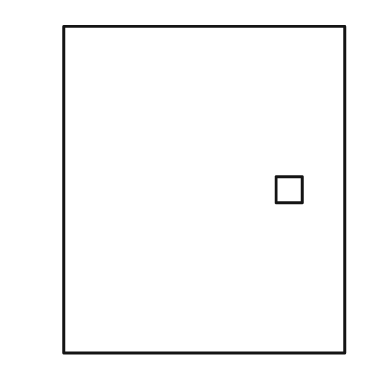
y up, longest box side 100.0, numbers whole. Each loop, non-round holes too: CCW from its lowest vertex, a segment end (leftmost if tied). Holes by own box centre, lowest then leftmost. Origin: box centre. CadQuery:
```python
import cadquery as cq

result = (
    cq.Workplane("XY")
    .moveTo(-43.0, -50.0)
    .lineTo(43.0, -50.0)
    .lineTo(43.0, 50.0)
    .lineTo(-43.0, 50.0)
    .close()
    .moveTo(22.0, -4.0)
    .lineTo(30.0, -4.0)
    .lineTo(30.0, 4.0)
    .lineTo(22.0, 4.0)
    .close()
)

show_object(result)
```